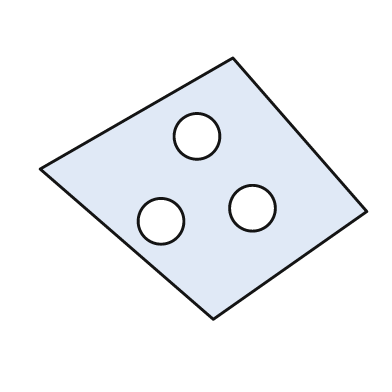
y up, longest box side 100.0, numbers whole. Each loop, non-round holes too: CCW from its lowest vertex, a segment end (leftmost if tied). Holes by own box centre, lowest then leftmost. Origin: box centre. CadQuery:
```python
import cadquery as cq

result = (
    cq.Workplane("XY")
    .moveTo(3.0, -40.0)
    .lineTo(50.0, -7.0)
    .lineTo(9.0, 40.0)
    .lineTo(-50.0, 6.0)
    .close()
    .moveTo(-13.0, -10.0)
    .circle(7.0)
    .moveTo(15.0, -6.0)
    .circle(7.0)
    .moveTo(-2.0, 16.0)
    .circle(7.0)
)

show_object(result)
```